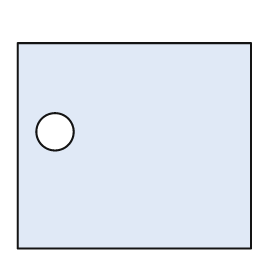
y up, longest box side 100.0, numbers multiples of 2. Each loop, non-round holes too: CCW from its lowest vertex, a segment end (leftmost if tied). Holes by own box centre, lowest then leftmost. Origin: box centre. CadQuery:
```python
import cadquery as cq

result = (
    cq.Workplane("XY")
    .moveTo(-50.0, -44.0)
    .lineTo(50.0, -44.0)
    .lineTo(50.0, 44.0)
    .lineTo(-50.0, 44.0)
    .close()
    .moveTo(-34.0, 6.0)
    .circle(8.0)
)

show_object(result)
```